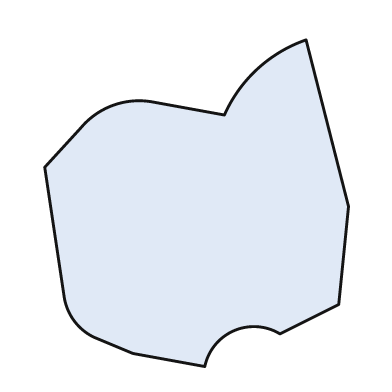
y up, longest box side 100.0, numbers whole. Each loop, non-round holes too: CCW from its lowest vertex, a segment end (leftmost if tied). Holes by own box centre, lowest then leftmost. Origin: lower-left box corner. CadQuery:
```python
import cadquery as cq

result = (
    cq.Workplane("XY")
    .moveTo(49.0, 0.0)
    .threePointArc((58.0, 11.0), (72.0, 10.0))
    .lineTo(90.0, 19.0)
    .lineTo(93.0, 49.0)
    .lineTo(80.0, 100.0)
    .threePointArc((65.0, 91.0), (55.0, 77.0))
    .lineTo(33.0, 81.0)
    .threePointArc((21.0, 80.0), (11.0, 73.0))
    .lineTo(0.0, 61.0)
    .lineTo(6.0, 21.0)
    .threePointArc((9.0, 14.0), (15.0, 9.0))
    .lineTo(27.0, 4.0)
    .close()
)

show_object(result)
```